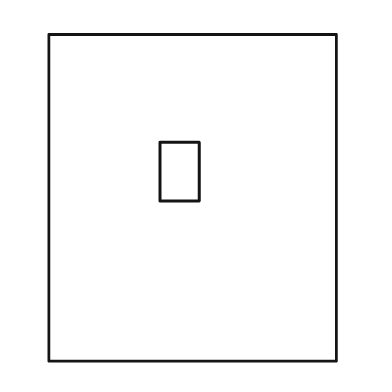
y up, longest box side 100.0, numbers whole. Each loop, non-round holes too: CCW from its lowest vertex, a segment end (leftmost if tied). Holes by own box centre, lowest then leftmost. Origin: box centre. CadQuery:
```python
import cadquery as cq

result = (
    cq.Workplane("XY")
    .moveTo(-44.0, -50.0)
    .lineTo(44.0, -50.0)
    .lineTo(44.0, 50.0)
    .lineTo(-44.0, 50.0)
    .close()
    .moveTo(-10.0, -1.0)
    .lineTo(2.0, -1.0)
    .lineTo(2.0, 17.0)
    .lineTo(-10.0, 17.0)
    .close()
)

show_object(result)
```